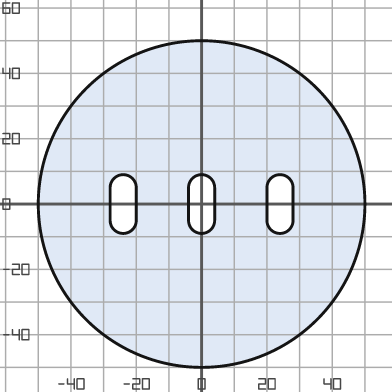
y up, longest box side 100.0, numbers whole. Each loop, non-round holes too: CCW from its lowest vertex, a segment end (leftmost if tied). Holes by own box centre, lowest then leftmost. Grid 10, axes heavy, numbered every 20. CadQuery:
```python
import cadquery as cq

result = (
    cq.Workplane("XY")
    .moveTo(0.0, 0.0)
    .circle(50.0)
    .moveTo(-28.0, -5.0)
    .threePointArc((-24.0, -9.0), (-20.0, -5.0))
    .lineTo(-20.0, 5.0)
    .threePointArc((-24.0, 9.0), (-28.0, 5.0))
    .close()
    .moveTo(-4.0, -5.0)
    .threePointArc((0.0, -9.0), (4.0, -5.0))
    .lineTo(4.0, 5.0)
    .threePointArc((0.0, 9.0), (-4.0, 5.0))
    .close()
    .moveTo(20.0, -5.0)
    .threePointArc((24.0, -9.0), (28.0, -5.0))
    .lineTo(28.0, 5.0)
    .threePointArc((24.0, 9.0), (20.0, 5.0))
    .close()
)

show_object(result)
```